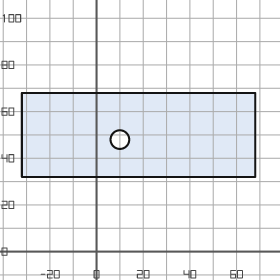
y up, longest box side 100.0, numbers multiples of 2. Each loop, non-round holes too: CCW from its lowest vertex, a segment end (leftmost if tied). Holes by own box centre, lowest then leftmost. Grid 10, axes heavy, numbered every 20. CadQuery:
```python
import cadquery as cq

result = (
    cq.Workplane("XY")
    .moveTo(-32.0, 32.0)
    .lineTo(68.0, 32.0)
    .lineTo(68.0, 68.0)
    .lineTo(-32.0, 68.0)
    .close()
    .moveTo(10.0, 48.0)
    .circle(4.0)
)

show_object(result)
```